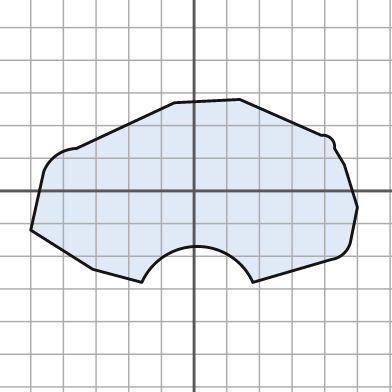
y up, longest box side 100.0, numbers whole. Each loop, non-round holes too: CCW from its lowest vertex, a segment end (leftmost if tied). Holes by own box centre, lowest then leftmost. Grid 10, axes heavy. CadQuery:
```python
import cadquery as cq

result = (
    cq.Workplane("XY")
    .moveTo(-16.0, -28.0)
    .threePointArc((1.0, -17.0), (18.0, -28.0))
    .lineTo(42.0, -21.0)
    .threePointArc((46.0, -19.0), (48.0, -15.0))
    .lineTo(50.0, -5.0)
    .lineTo(46.0, 8.0)
    .lineTo(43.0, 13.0)
    .threePointArc((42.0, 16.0), (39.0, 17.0))
    .lineTo(14.0, 28.0)
    .lineTo(-6.0, 27.0)
    .lineTo(-36.0, 13.0)
    .threePointArc((-42.0, 11.0), (-46.0, 6.0))
    .lineTo(-50.0, -12.0)
    .lineTo(-31.0, -24.0)
    .close()
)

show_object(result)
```